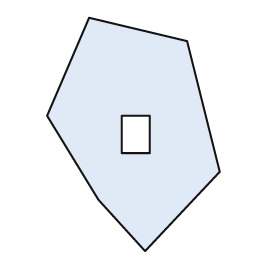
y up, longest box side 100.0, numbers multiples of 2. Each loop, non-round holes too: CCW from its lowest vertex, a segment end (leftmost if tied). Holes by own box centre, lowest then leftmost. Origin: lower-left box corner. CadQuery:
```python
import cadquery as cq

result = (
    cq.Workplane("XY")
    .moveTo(42.0, 0.0)
    .lineTo(74.0, 34.0)
    .lineTo(60.0, 90.0)
    .lineTo(18.0, 100.0)
    .lineTo(0.0, 58.0)
    .lineTo(22.0, 22.0)
    .close()
    .moveTo(32.0, 42.0)
    .lineTo(44.0, 42.0)
    .lineTo(44.0, 58.0)
    .lineTo(32.0, 58.0)
    .close()
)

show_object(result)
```